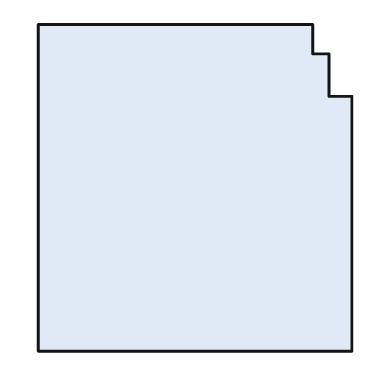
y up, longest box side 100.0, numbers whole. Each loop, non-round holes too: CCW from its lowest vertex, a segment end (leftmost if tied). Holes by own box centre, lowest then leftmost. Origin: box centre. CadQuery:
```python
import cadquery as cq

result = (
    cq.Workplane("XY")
    .moveTo(-48.0, -50.0)
    .lineTo(48.0, -50.0)
    .lineTo(48.0, 28.0)
    .lineTo(41.0, 28.0)
    .lineTo(41.0, 41.0)
    .lineTo(36.0, 41.0)
    .lineTo(36.0, 50.0)
    .lineTo(-48.0, 50.0)
    .close()
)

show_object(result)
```